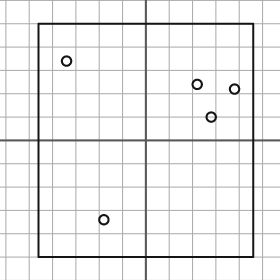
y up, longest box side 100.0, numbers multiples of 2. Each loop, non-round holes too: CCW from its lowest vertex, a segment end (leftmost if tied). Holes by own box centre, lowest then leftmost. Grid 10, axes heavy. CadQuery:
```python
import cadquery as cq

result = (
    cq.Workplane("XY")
    .moveTo(-46.0, -50.0)
    .lineTo(46.0, -50.0)
    .lineTo(46.0, 50.0)
    .lineTo(-46.0, 50.0)
    .close()
    .moveTo(-18.0, -34.0)
    .circle(2.0)
    .moveTo(28.0, 10.0)
    .circle(2.0)
    .moveTo(38.0, 22.0)
    .circle(2.0)
    .moveTo(22.0, 24.0)
    .circle(2.0)
    .moveTo(-34.0, 34.0)
    .circle(2.0)
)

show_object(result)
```